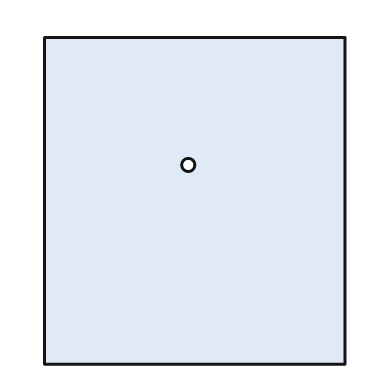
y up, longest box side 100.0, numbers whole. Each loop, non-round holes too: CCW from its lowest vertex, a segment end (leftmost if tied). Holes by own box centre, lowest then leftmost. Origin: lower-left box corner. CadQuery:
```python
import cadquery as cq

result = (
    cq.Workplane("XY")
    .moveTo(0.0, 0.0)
    .lineTo(92.0, 0.0)
    .lineTo(92.0, 100.0)
    .lineTo(0.0, 100.0)
    .close()
    .moveTo(44.0, 61.0)
    .circle(2.0)
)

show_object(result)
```